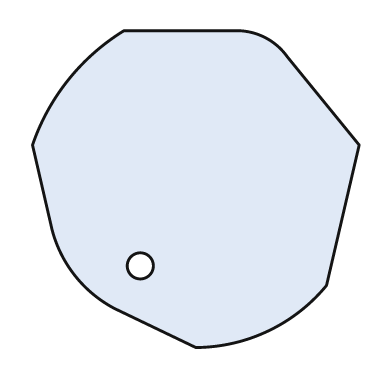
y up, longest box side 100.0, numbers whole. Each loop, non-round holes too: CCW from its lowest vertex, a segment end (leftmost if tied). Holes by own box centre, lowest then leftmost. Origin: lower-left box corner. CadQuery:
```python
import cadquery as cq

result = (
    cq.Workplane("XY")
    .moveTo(50.0, 0.0)
    .threePointArc((72.0, 5.0), (90.0, 19.0))
    .lineTo(100.0, 62.0)
    .lineTo(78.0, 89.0)
    .threePointArc((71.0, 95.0), (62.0, 97.0))
    .lineTo(28.0, 97.0)
    .threePointArc((11.0, 82.0), (0.0, 62.0))
    .lineTo(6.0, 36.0)
    .threePointArc((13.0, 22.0), (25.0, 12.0))
    .close()
    .moveTo(33.0, 25.0)
    .circle(4.0)
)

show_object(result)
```